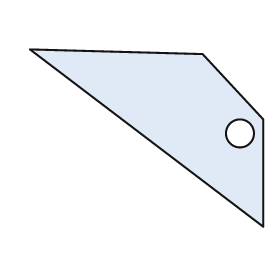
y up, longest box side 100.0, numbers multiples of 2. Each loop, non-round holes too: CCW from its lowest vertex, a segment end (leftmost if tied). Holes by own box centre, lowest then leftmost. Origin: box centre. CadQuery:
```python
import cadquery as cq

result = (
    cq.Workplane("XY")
    .moveTo(50.0, -38.0)
    .lineTo(50.0, 8.0)
    .lineTo(24.0, 36.0)
    .lineTo(-50.0, 38.0)
    .close()
    .moveTo(40.0, 2.0)
    .circle(6.0)
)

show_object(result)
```